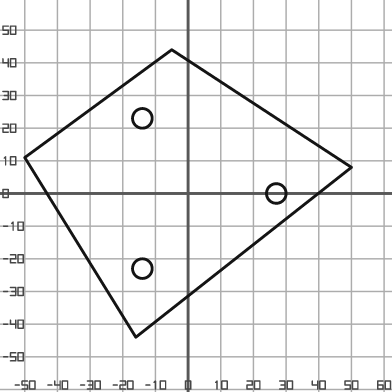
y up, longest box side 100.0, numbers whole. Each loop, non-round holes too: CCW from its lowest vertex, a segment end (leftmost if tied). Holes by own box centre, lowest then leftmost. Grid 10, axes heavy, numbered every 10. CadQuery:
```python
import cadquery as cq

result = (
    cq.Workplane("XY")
    .moveTo(-16.0, -44.0)
    .lineTo(50.0, 8.0)
    .lineTo(-5.0, 44.0)
    .lineTo(-50.0, 11.0)
    .close()
    .moveTo(-14.0, -23.0)
    .circle(3.0)
    .moveTo(27.0, 0.0)
    .circle(3.0)
    .moveTo(-14.0, 23.0)
    .circle(3.0)
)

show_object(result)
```